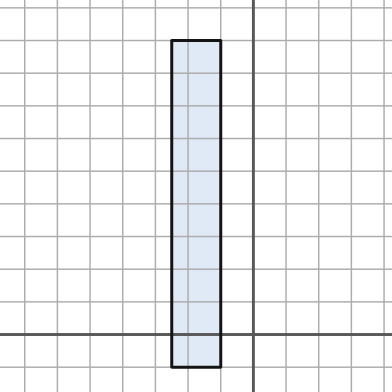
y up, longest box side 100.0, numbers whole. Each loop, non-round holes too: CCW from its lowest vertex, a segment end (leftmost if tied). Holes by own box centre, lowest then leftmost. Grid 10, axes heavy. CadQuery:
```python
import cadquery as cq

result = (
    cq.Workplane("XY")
    .moveTo(-25.0, -10.0)
    .lineTo(-10.0, -10.0)
    .lineTo(-10.0, 90.0)
    .lineTo(-25.0, 90.0)
    .close()
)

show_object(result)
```